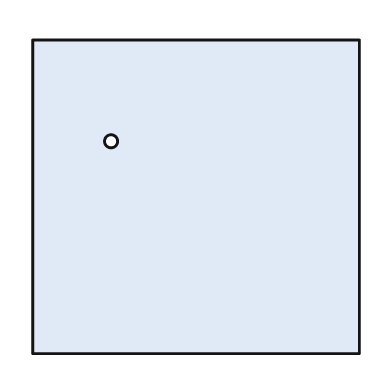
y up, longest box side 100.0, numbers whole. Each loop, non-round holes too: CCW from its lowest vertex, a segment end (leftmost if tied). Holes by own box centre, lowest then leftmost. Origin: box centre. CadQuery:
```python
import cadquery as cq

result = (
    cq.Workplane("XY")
    .moveTo(-50.0, -48.0)
    .lineTo(50.0, -48.0)
    .lineTo(50.0, 48.0)
    .lineTo(-50.0, 48.0)
    .close()
    .moveTo(-26.0, 17.0)
    .circle(2.0)
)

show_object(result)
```